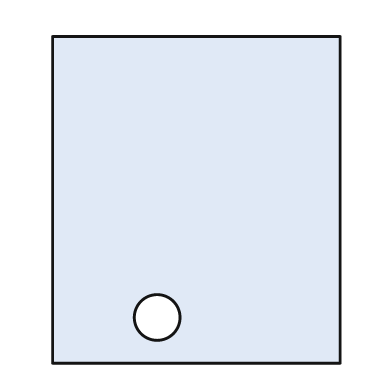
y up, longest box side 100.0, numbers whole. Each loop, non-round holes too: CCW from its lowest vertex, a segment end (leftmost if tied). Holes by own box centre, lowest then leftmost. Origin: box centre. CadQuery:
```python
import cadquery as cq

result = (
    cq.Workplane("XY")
    .moveTo(-44.0, -50.0)
    .lineTo(44.0, -50.0)
    .lineTo(44.0, 50.0)
    .lineTo(-44.0, 50.0)
    .close()
    .moveTo(-12.0, -36.0)
    .circle(7.0)
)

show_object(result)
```